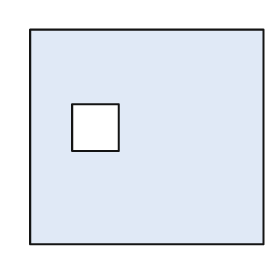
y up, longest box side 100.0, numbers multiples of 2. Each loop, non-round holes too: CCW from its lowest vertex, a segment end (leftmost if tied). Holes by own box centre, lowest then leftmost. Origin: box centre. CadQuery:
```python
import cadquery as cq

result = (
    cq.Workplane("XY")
    .moveTo(-50.0, -46.0)
    .lineTo(50.0, -46.0)
    .lineTo(50.0, 46.0)
    .lineTo(-50.0, 46.0)
    .close()
    .moveTo(-32.0, -6.0)
    .lineTo(-12.0, -6.0)
    .lineTo(-12.0, 14.0)
    .lineTo(-32.0, 14.0)
    .close()
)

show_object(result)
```